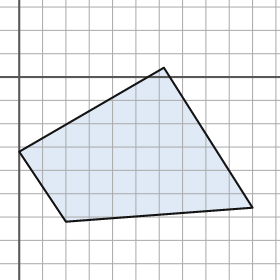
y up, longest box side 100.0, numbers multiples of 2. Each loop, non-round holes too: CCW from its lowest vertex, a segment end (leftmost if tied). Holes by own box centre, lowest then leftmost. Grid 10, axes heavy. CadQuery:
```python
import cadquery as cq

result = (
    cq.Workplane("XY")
    .moveTo(20.0, -62.0)
    .lineTo(100.0, -56.0)
    .lineTo(62.0, 4.0)
    .lineTo(0.0, -32.0)
    .close()
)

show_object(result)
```